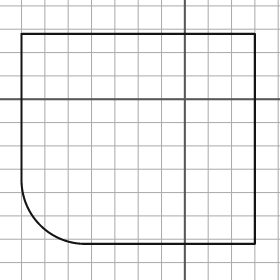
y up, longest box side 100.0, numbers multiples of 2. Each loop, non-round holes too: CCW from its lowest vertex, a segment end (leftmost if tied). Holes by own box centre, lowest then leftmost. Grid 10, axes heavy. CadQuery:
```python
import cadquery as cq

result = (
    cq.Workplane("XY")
    .moveTo(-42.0, -62.0)
    .lineTo(30.0, -62.0)
    .lineTo(30.0, 28.0)
    .lineTo(-70.0, 28.0)
    .lineTo(-70.0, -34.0)
    .threePointArc((-62.0, -54.0), (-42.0, -62.0))
    .close()
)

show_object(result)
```